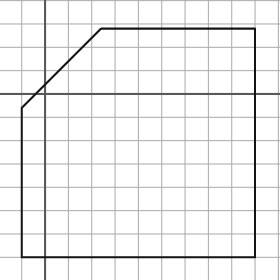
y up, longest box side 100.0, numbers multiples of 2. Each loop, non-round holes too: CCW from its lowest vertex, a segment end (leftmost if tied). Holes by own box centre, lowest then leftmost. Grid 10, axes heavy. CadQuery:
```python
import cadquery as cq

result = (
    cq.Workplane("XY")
    .moveTo(-10.0, -70.0)
    .lineTo(90.0, -70.0)
    .lineTo(90.0, 28.0)
    .lineTo(24.0, 28.0)
    .lineTo(-10.0, -6.0)
    .close()
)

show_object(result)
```